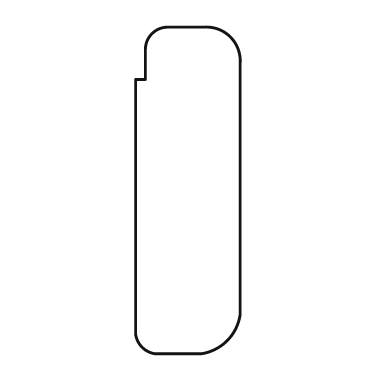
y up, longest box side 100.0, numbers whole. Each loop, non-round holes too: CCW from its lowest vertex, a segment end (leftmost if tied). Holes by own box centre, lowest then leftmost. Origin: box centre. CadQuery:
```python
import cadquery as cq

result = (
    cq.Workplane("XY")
    .moveTo(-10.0, -50.0)
    .lineTo(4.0, -50.0)
    .threePointArc((12.0, -46.0), (16.0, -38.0))
    .lineTo(16.0, 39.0)
    .threePointArc((13.0, 47.0), (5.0, 50.0))
    .lineTo(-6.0, 50.0)
    .threePointArc((-11.0, 48.0), (-13.0, 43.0))
    .lineTo(-13.0, 34.0)
    .lineTo(-16.0, 34.0)
    .lineTo(-16.0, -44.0)
    .threePointArc((-14.0, -48.0), (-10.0, -50.0))
    .close()
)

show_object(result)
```